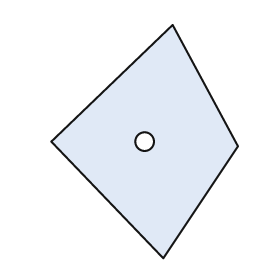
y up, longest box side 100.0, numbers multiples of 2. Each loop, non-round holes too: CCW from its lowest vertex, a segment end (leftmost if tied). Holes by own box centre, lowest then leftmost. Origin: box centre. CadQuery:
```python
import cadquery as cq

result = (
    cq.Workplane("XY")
    .moveTo(8.0, -50.0)
    .lineTo(40.0, -2.0)
    .lineTo(12.0, 50.0)
    .lineTo(-40.0, 0.0)
    .close()
    .moveTo(0.0, 0.0)
    .circle(4.0)
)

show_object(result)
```